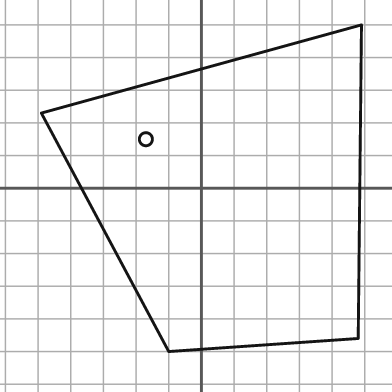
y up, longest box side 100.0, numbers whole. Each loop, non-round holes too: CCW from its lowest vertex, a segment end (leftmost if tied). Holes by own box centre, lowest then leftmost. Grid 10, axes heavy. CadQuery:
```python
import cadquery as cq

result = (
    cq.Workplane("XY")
    .moveTo(-10.0, -50.0)
    .lineTo(48.0, -46.0)
    .lineTo(49.0, 50.0)
    .lineTo(-49.0, 23.0)
    .close()
    .moveTo(-17.0, 15.0)
    .circle(2.0)
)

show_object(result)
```